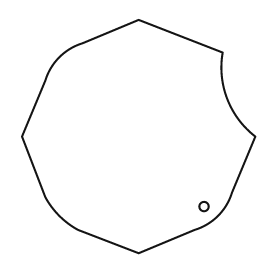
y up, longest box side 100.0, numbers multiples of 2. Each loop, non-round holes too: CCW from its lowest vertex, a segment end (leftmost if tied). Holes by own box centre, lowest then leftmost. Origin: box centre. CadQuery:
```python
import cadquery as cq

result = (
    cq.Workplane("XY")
    .moveTo(0.0, -50.0)
    .lineTo(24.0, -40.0)
    .threePointArc((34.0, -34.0), (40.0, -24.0))
    .lineTo(50.0, 0.0)
    .threePointArc((38.0, 16.0), (36.0, 36.0))
    .lineTo(0.0, 50.0)
    .lineTo(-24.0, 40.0)
    .threePointArc((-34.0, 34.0), (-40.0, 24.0))
    .lineTo(-50.0, 0.0)
    .lineTo(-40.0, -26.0)
    .threePointArc((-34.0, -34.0), (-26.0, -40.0))
    .close()
    .moveTo(28.0, -30.0)
    .circle(2.0)
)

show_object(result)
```